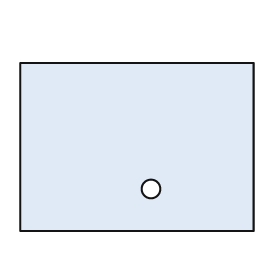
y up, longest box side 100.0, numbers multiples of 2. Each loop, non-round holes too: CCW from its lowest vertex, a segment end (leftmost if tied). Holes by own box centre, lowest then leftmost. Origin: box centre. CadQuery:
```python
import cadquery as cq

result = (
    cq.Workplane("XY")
    .moveTo(-50.0, -36.0)
    .lineTo(50.0, -36.0)
    .lineTo(50.0, 36.0)
    .lineTo(-50.0, 36.0)
    .close()
    .moveTo(6.0, -18.0)
    .circle(4.0)
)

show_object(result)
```